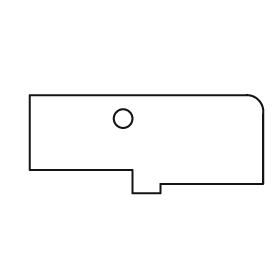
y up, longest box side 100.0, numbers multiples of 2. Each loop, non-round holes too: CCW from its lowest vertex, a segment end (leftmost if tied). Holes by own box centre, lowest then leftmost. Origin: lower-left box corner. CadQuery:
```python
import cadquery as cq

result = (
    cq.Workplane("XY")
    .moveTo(44.0, 0.0)
    .lineTo(56.0, 0.0)
    .lineTo(56.0, 4.0)
    .lineTo(100.0, 4.0)
    .lineTo(100.0, 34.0)
    .threePointArc((98.0, 40.0), (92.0, 42.0))
    .lineTo(0.0, 42.0)
    .lineTo(0.0, 10.0)
    .lineTo(44.0, 10.0)
    .close()
    .moveTo(40.0, 32.0)
    .circle(4.0)
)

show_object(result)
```